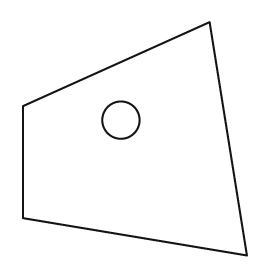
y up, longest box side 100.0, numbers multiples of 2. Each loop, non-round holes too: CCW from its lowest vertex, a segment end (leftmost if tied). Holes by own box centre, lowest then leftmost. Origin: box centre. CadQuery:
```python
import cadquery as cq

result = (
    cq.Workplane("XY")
    .moveTo(48.0, -50.0)
    .lineTo(32.0, 50.0)
    .lineTo(-48.0, 14.0)
    .lineTo(-48.0, -34.0)
    .close()
    .moveTo(-6.0, 8.0)
    .circle(8.0)
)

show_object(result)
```